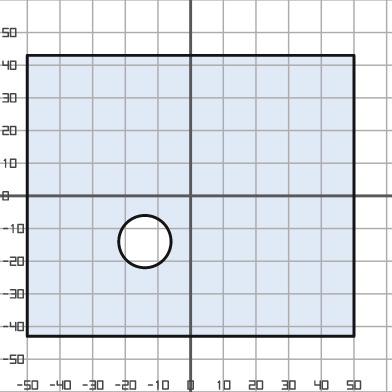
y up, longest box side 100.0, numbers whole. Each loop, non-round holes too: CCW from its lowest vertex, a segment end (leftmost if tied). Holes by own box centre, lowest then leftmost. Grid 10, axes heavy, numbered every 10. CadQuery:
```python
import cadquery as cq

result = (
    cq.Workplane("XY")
    .moveTo(-50.0, -43.0)
    .lineTo(50.0, -43.0)
    .lineTo(50.0, 43.0)
    .lineTo(-50.0, 43.0)
    .close()
    .moveTo(-14.0, -14.0)
    .circle(8.0)
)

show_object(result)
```